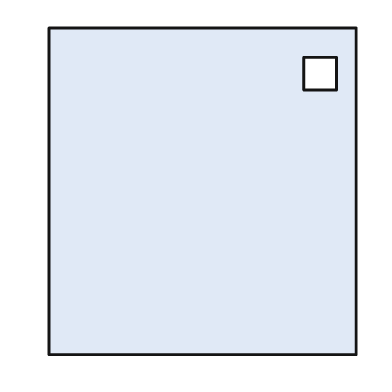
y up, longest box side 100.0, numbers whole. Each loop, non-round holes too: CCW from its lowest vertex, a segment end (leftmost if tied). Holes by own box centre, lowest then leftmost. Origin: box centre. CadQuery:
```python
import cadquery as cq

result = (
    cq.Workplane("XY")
    .moveTo(-47.0, -50.0)
    .lineTo(47.0, -50.0)
    .lineTo(47.0, 50.0)
    .lineTo(-47.0, 50.0)
    .close()
    .moveTo(31.0, 31.0)
    .lineTo(41.0, 31.0)
    .lineTo(41.0, 41.0)
    .lineTo(31.0, 41.0)
    .close()
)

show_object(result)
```